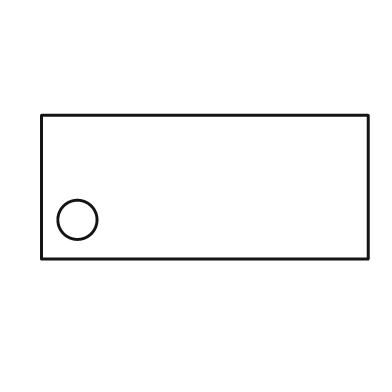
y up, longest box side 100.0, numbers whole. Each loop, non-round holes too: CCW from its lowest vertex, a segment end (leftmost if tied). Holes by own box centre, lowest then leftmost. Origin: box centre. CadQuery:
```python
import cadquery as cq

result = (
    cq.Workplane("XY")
    .moveTo(-50.0, -22.0)
    .lineTo(50.0, -22.0)
    .lineTo(50.0, 22.0)
    .lineTo(-50.0, 22.0)
    .close()
    .moveTo(-39.0, -10.0)
    .circle(6.0)
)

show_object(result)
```